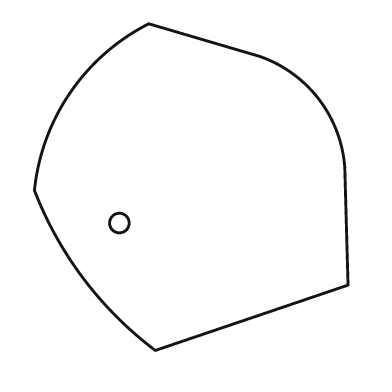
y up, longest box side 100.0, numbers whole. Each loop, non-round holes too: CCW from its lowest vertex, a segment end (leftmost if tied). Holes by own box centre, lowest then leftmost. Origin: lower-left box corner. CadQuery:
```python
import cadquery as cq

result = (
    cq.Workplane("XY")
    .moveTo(37.0, 0.0)
    .lineTo(96.0, 20.0)
    .lineTo(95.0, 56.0)
    .threePointArc((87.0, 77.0), (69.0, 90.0))
    .lineTo(35.0, 100.0)
    .threePointArc((11.0, 79.0), (0.0, 49.0))
    .threePointArc((15.0, 22.0), (37.0, 0.0))
    .close()
    .moveTo(26.0, 39.0)
    .circle(3.0)
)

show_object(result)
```